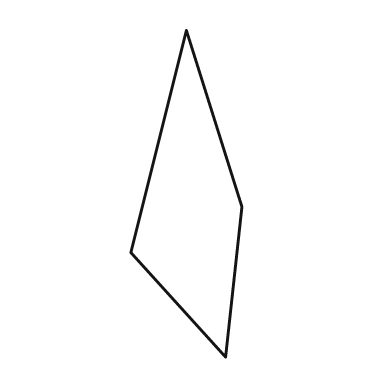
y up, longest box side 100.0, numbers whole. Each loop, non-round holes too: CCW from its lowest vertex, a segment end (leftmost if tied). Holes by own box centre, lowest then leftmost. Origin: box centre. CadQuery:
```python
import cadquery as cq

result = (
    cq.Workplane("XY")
    .moveTo(12.0, -50.0)
    .lineTo(17.0, -4.0)
    .lineTo(0.0, 50.0)
    .lineTo(-17.0, -18.0)
    .close()
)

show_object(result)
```